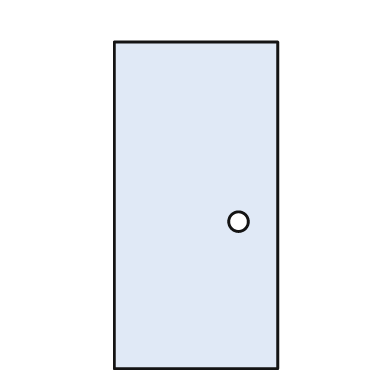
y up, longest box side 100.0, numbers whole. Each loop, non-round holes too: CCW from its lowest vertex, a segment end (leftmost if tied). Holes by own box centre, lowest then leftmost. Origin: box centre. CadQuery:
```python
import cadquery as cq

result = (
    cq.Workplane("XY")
    .moveTo(-25.0, -50.0)
    .lineTo(25.0, -50.0)
    .lineTo(25.0, 50.0)
    .lineTo(-25.0, 50.0)
    .close()
    .moveTo(13.0, -5.0)
    .circle(3.0)
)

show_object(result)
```